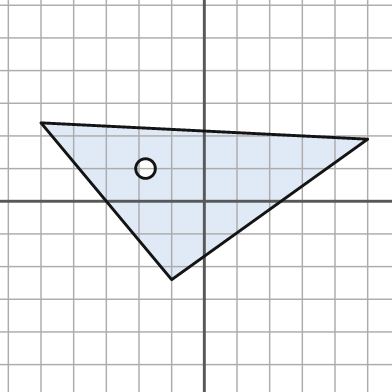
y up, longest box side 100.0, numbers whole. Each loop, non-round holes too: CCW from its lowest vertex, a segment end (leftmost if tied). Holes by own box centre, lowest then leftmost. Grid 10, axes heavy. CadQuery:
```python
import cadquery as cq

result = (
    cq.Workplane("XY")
    .moveTo(-10.0, -24.0)
    .lineTo(50.0, 19.0)
    .lineTo(-50.0, 24.0)
    .close()
    .moveTo(-18.0, 10.0)
    .circle(3.0)
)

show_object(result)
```